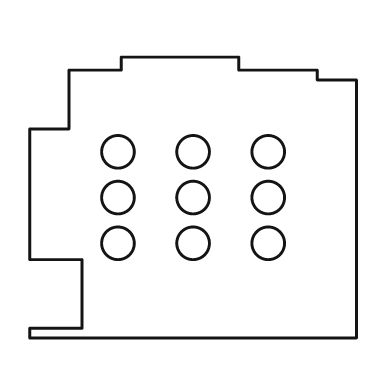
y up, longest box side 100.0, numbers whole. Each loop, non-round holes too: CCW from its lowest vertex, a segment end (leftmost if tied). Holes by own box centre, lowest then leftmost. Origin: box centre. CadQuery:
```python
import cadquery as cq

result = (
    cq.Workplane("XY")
    .moveTo(-50.0, -43.0)
    .lineTo(50.0, -43.0)
    .lineTo(50.0, 36.0)
    .lineTo(38.0, 36.0)
    .lineTo(38.0, 39.0)
    .lineTo(14.0, 39.0)
    .lineTo(14.0, 43.0)
    .lineTo(-22.0, 43.0)
    .lineTo(-22.0, 39.0)
    .lineTo(-38.0, 39.0)
    .lineTo(-38.0, 21.0)
    .lineTo(-50.0, 21.0)
    .lineTo(-50.0, -19.0)
    .lineTo(-34.0, -19.0)
    .lineTo(-34.0, -40.0)
    .lineTo(-50.0, -40.0)
    .close()
    .moveTo(-23.0, -14.0)
    .circle(5.0)
    .moveTo(0.0, -14.0)
    .circle(5.0)
    .moveTo(23.0, -14.0)
    .circle(5.0)
    .moveTo(-23.0, 0.0)
    .circle(5.0)
    .moveTo(0.0, 0.0)
    .circle(5.0)
    .moveTo(23.0, 0.0)
    .circle(5.0)
    .moveTo(-23.0, 14.0)
    .circle(5.0)
    .moveTo(0.0, 14.0)
    .circle(5.0)
    .moveTo(23.0, 14.0)
    .circle(5.0)
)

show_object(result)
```